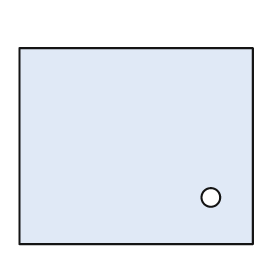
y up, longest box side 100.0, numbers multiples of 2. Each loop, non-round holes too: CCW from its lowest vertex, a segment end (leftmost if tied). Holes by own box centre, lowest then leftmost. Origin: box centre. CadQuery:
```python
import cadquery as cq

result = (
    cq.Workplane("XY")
    .moveTo(-50.0, -42.0)
    .lineTo(50.0, -42.0)
    .lineTo(50.0, 42.0)
    .lineTo(-50.0, 42.0)
    .close()
    .moveTo(32.0, -22.0)
    .circle(4.0)
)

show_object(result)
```